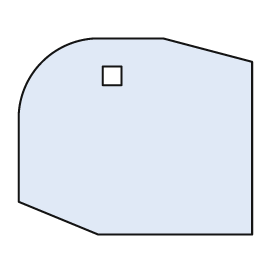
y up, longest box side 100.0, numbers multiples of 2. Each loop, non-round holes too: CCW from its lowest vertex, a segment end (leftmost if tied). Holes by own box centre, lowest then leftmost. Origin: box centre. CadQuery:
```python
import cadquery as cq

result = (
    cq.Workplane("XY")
    .moveTo(-16.0, -42.0)
    .lineTo(50.0, -42.0)
    .lineTo(50.0, 32.0)
    .lineTo(12.0, 42.0)
    .lineTo(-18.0, 42.0)
    .threePointArc((-40.0, 32.0), (-50.0, 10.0))
    .lineTo(-50.0, -28.0)
    .close()
    .moveTo(-14.0, 22.0)
    .lineTo(-6.0, 22.0)
    .lineTo(-6.0, 30.0)
    .lineTo(-14.0, 30.0)
    .close()
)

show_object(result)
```